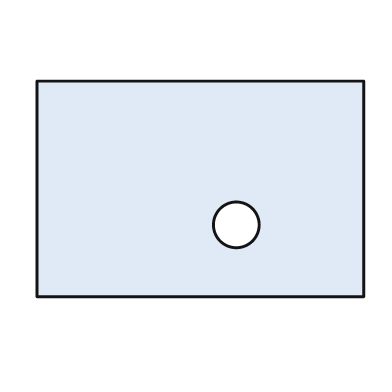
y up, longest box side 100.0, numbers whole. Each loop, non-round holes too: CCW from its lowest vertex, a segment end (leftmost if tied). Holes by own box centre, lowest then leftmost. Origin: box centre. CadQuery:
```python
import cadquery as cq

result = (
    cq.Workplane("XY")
    .moveTo(-50.0, -33.0)
    .lineTo(50.0, -33.0)
    .lineTo(50.0, 33.0)
    .lineTo(-50.0, 33.0)
    .close()
    .moveTo(11.0, -11.0)
    .circle(7.0)
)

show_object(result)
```